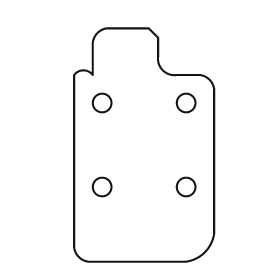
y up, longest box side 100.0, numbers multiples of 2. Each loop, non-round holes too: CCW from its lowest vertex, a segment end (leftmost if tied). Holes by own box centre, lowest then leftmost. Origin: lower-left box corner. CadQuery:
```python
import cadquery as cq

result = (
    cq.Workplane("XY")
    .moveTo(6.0, 0.0)
    .lineTo(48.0, 0.0)
    .threePointArc((56.0, 4.0), (60.0, 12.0))
    .lineTo(60.0, 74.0)
    .threePointArc((58.0, 78.0), (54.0, 80.0))
    .lineTo(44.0, 80.0)
    .threePointArc((38.0, 82.0), (36.0, 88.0))
    .lineTo(36.0, 96.0)
    .lineTo(32.0, 100.0)
    .lineTo(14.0, 100.0)
    .threePointArc((10.0, 98.0), (8.0, 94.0))
    .lineTo(8.0, 80.0)
    .threePointArc((4.0, 82.0), (0.0, 80.0))
    .lineTo(0.0, 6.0)
    .threePointArc((2.0, 2.0), (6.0, 0.0))
    .close()
    .moveTo(12.0, 32.0)
    .circle(4.0)
    .moveTo(48.0, 32.0)
    .circle(4.0)
    .moveTo(12.0, 68.0)
    .circle(4.0)
    .moveTo(48.0, 68.0)
    .circle(4.0)
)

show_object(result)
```